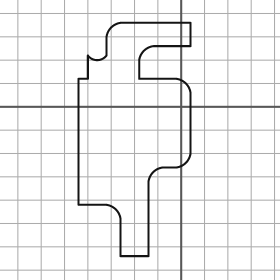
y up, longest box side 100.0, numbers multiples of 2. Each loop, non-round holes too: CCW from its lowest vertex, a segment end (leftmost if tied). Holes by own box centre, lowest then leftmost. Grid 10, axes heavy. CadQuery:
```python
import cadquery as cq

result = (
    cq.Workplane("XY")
    .moveTo(-26.0, -64.0)
    .lineTo(-14.0, -64.0)
    .lineTo(-14.0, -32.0)
    .threePointArc((-12.0, -28.0), (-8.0, -26.0))
    .lineTo(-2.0, -26.0)
    .threePointArc((2.0, -24.0), (4.0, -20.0))
    .lineTo(4.0, 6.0)
    .threePointArc((2.0, 10.0), (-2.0, 12.0))
    .lineTo(-18.0, 12.0)
    .lineTo(-18.0, 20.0)
    .threePointArc((-16.0, 24.0), (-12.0, 26.0))
    .lineTo(4.0, 26.0)
    .lineTo(4.0, 36.0)
    .lineTo(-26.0, 36.0)
    .threePointArc((-30.0, 34.0), (-32.0, 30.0))
    .lineTo(-32.0, 22.0)
    .threePointArc((-36.0, 20.0), (-40.0, 22.0))
    .lineTo(-40.0, 12.0)
    .lineTo(-44.0, 12.0)
    .lineTo(-44.0, -42.0)
    .lineTo(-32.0, -42.0)
    .threePointArc((-28.0, -44.0), (-26.0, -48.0))
    .close()
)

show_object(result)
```